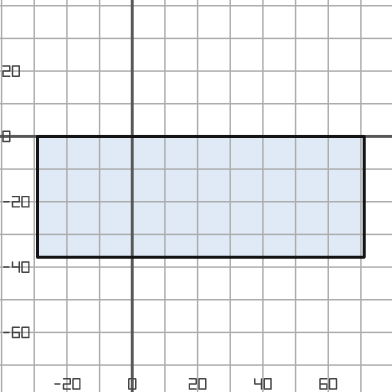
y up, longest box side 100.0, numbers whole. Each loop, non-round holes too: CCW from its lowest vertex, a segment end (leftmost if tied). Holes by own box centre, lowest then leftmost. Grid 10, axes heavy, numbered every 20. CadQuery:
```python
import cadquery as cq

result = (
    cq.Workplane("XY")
    .moveTo(-29.0, -37.0)
    .lineTo(71.0, -37.0)
    .lineTo(71.0, 0.0)
    .lineTo(-29.0, 0.0)
    .close()
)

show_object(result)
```